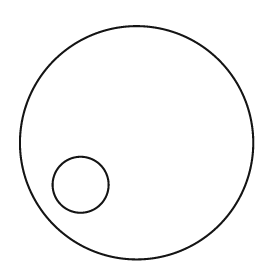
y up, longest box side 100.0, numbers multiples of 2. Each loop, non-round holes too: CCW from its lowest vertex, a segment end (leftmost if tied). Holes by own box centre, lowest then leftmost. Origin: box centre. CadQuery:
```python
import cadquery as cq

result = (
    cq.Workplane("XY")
    .moveTo(0.0, 0.0)
    .circle(50.0)
    .moveTo(-24.0, -18.0)
    .circle(12.0)
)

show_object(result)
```